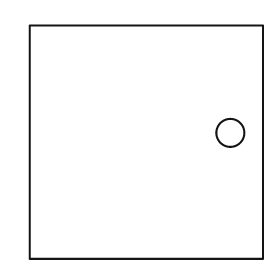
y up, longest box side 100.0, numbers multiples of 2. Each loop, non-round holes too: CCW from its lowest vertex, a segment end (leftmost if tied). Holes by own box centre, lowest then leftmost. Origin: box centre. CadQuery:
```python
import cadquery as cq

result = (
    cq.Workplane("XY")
    .moveTo(-50.0, -50.0)
    .lineTo(50.0, -50.0)
    .lineTo(50.0, 50.0)
    .lineTo(-50.0, 50.0)
    .close()
    .moveTo(36.0, 4.0)
    .circle(6.0)
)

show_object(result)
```